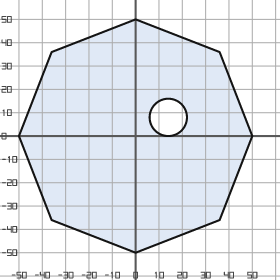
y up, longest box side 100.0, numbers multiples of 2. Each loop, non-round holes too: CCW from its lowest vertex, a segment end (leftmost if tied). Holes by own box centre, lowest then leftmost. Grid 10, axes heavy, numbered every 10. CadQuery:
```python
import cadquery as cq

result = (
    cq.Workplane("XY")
    .moveTo(0.0, -50.0)
    .lineTo(36.0, -36.0)
    .lineTo(50.0, 0.0)
    .lineTo(36.0, 36.0)
    .lineTo(0.0, 50.0)
    .lineTo(-36.0, 36.0)
    .lineTo(-50.0, 0.0)
    .lineTo(-36.0, -36.0)
    .close()
    .moveTo(14.0, 8.0)
    .circle(8.0)
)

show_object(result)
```